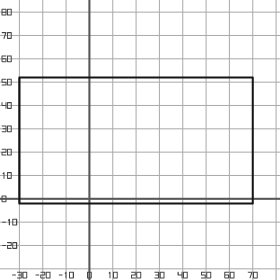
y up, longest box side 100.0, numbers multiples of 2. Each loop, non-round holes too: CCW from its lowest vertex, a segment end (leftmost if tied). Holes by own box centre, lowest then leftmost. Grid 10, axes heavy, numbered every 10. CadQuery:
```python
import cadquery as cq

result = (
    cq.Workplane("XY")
    .moveTo(-30.0, -2.0)
    .lineTo(70.0, -2.0)
    .lineTo(70.0, 52.0)
    .lineTo(-30.0, 52.0)
    .close()
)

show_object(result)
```